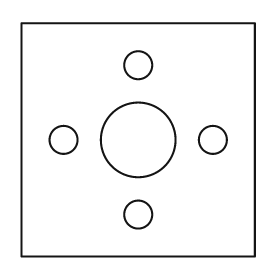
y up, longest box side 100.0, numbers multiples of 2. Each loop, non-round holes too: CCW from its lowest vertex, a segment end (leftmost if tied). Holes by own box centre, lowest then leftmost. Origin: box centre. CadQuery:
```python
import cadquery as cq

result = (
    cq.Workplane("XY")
    .moveTo(-50.0, -50.0)
    .lineTo(50.0, -50.0)
    .lineTo(50.0, 50.0)
    .lineTo(-50.0, 50.0)
    .close()
    .moveTo(0.0, -32.0)
    .circle(6.0)
    .moveTo(-32.0, 0.0)
    .circle(6.0)
    .moveTo(0.0, 0.0)
    .circle(16.0)
    .moveTo(32.0, 0.0)
    .circle(6.0)
    .moveTo(0.0, 32.0)
    .circle(6.0)
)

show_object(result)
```